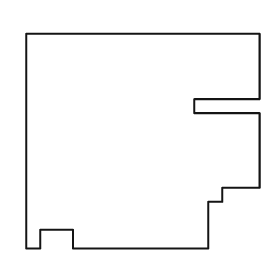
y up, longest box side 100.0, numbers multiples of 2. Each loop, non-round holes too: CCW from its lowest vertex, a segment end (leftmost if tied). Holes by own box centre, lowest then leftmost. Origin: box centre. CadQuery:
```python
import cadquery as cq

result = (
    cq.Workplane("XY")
    .moveTo(-50.0, -46.0)
    .lineTo(-44.0, -46.0)
    .lineTo(-44.0, -38.0)
    .lineTo(-30.0, -38.0)
    .lineTo(-30.0, -46.0)
    .lineTo(28.0, -46.0)
    .lineTo(28.0, -26.0)
    .lineTo(34.0, -26.0)
    .lineTo(34.0, -20.0)
    .lineTo(50.0, -20.0)
    .lineTo(50.0, 12.0)
    .lineTo(22.0, 12.0)
    .lineTo(22.0, 18.0)
    .lineTo(50.0, 18.0)
    .lineTo(50.0, 46.0)
    .lineTo(-50.0, 46.0)
    .close()
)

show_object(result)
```